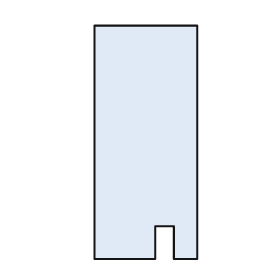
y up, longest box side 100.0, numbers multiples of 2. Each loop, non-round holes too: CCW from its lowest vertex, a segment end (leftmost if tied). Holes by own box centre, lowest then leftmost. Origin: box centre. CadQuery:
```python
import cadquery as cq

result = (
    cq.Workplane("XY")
    .moveTo(-22.0, -50.0)
    .lineTo(4.0, -50.0)
    .lineTo(4.0, -36.0)
    .lineTo(12.0, -36.0)
    .lineTo(12.0, -50.0)
    .lineTo(22.0, -50.0)
    .lineTo(22.0, 50.0)
    .lineTo(-22.0, 50.0)
    .close()
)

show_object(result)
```